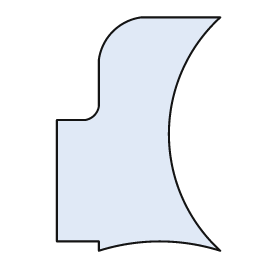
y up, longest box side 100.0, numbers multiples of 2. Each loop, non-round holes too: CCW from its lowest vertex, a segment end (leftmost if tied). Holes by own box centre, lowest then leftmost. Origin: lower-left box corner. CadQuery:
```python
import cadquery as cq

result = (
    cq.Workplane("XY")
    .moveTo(18.0, 0.0)
    .threePointArc((44.0, 4.0), (70.0, 0.0))
    .threePointArc((48.0, 50.0), (70.0, 100.0))
    .lineTo(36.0, 100.0)
    .threePointArc((24.0, 94.0), (18.0, 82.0))
    .lineTo(18.0, 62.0)
    .threePointArc((16.0, 58.0), (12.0, 56.0))
    .lineTo(0.0, 56.0)
    .lineTo(0.0, 4.0)
    .lineTo(18.0, 4.0)
    .close()
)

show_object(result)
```